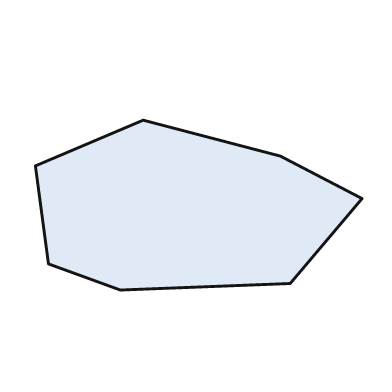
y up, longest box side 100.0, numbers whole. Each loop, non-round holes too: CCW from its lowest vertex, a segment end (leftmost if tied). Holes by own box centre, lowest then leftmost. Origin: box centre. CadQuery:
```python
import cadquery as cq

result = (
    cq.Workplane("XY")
    .moveTo(-24.0, -26.0)
    .lineTo(28.0, -24.0)
    .lineTo(50.0, 2.0)
    .lineTo(25.0, 15.0)
    .lineTo(-17.0, 26.0)
    .lineTo(-50.0, 12.0)
    .lineTo(-46.0, -18.0)
    .close()
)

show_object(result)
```